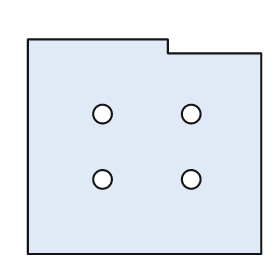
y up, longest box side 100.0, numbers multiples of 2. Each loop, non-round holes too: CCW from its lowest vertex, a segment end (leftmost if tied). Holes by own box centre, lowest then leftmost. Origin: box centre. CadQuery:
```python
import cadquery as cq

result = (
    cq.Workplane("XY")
    .moveTo(-50.0, -46.0)
    .lineTo(50.0, -46.0)
    .lineTo(50.0, 40.0)
    .lineTo(10.0, 40.0)
    .lineTo(10.0, 46.0)
    .lineTo(-50.0, 46.0)
    .close()
    .moveTo(-18.0, -14.0)
    .circle(4.0)
    .moveTo(20.0, -14.0)
    .circle(4.0)
    .moveTo(-18.0, 14.0)
    .circle(4.0)
    .moveTo(20.0, 14.0)
    .circle(4.0)
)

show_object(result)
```